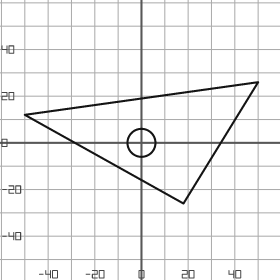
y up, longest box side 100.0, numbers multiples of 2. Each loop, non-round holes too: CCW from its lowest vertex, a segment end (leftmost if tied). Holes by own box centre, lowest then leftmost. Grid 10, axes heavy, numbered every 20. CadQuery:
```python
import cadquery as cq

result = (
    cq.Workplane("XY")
    .moveTo(18.0, -26.0)
    .lineTo(50.0, 26.0)
    .lineTo(-50.0, 12.0)
    .close()
    .moveTo(0.0, 0.0)
    .circle(6.0)
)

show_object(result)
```